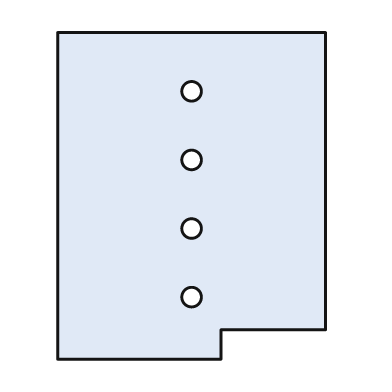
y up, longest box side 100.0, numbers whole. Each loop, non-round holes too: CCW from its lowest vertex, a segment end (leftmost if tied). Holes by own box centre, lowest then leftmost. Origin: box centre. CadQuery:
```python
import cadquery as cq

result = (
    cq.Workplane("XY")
    .moveTo(-41.0, -50.0)
    .lineTo(9.0, -50.0)
    .lineTo(9.0, -41.0)
    .lineTo(41.0, -41.0)
    .lineTo(41.0, 50.0)
    .lineTo(-41.0, 50.0)
    .close()
    .moveTo(0.0, -31.0)
    .circle(3.0)
    .moveTo(0.0, -10.0)
    .circle(3.0)
    .moveTo(0.0, 11.0)
    .circle(3.0)
    .moveTo(0.0, 32.0)
    .circle(3.0)
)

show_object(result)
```